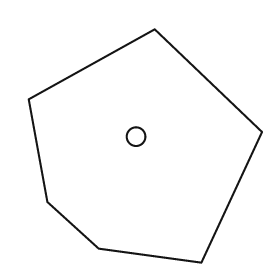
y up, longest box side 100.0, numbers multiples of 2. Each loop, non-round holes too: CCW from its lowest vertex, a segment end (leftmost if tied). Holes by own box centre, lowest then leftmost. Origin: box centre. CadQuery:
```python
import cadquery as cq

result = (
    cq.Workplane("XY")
    .moveTo(24.0, -50.0)
    .lineTo(50.0, 6.0)
    .lineTo(4.0, 50.0)
    .lineTo(-50.0, 20.0)
    .lineTo(-42.0, -24.0)
    .lineTo(-20.0, -44.0)
    .close()
    .moveTo(-4.0, 4.0)
    .circle(4.0)
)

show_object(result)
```